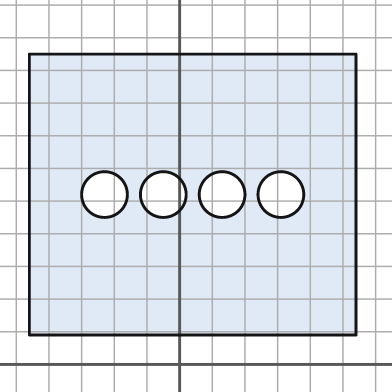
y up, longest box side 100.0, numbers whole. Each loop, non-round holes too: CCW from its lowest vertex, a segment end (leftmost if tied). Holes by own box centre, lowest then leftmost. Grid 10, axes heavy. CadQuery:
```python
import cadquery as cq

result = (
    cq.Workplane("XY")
    .moveTo(-46.0, 9.0)
    .lineTo(54.0, 9.0)
    .lineTo(54.0, 95.0)
    .lineTo(-46.0, 95.0)
    .close()
    .moveTo(-23.0, 52.0)
    .circle(7.0)
    .moveTo(-5.0, 52.0)
    .circle(7.0)
    .moveTo(13.0, 52.0)
    .circle(7.0)
    .moveTo(31.0, 52.0)
    .circle(7.0)
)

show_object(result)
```